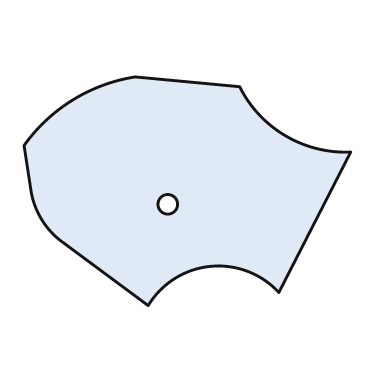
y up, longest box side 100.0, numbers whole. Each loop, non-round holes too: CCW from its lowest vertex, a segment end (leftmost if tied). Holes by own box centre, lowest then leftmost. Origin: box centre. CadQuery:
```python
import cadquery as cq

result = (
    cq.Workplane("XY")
    .moveTo(-12.0, -35.0)
    .threePointArc((7.0, -23.0), (28.0, -31.0))
    .lineTo(50.0, 12.0)
    .threePointArc((30.0, 17.0), (16.0, 32.0))
    .lineTo(-16.0, 35.0)
    .threePointArc((-35.0, 28.0), (-50.0, 14.0))
    .lineTo(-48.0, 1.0)
    .threePointArc((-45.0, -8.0), (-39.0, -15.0))
    .close()
    .moveTo(-6.0, -4.0)
    .circle(3.0)
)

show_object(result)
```